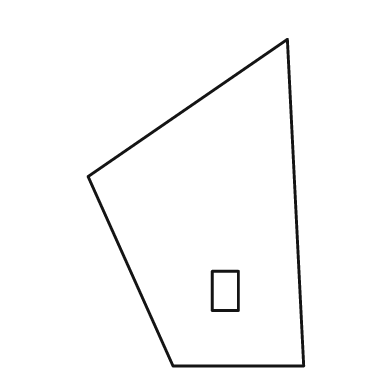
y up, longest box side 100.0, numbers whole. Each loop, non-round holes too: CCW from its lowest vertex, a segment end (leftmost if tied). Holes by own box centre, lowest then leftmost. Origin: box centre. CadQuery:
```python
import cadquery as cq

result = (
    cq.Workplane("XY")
    .moveTo(-7.0, -50.0)
    .lineTo(33.0, -50.0)
    .lineTo(28.0, 50.0)
    .lineTo(-33.0, 8.0)
    .close()
    .moveTo(5.0, -33.0)
    .lineTo(13.0, -33.0)
    .lineTo(13.0, -21.0)
    .lineTo(5.0, -21.0)
    .close()
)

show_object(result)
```